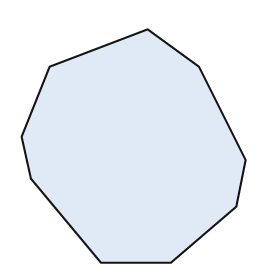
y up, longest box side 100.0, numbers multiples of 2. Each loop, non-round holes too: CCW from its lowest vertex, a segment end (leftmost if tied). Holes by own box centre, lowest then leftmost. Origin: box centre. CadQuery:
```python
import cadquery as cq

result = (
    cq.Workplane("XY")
    .moveTo(-14.0, -50.0)
    .lineTo(16.0, -50.0)
    .lineTo(44.0, -26.0)
    .lineTo(48.0, -6.0)
    .lineTo(28.0, 34.0)
    .lineTo(6.0, 50.0)
    .lineTo(-36.0, 34.0)
    .lineTo(-48.0, 4.0)
    .lineTo(-44.0, -14.0)
    .close()
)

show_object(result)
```